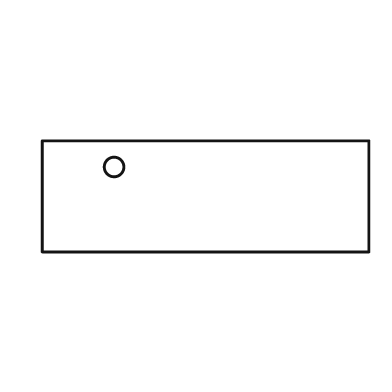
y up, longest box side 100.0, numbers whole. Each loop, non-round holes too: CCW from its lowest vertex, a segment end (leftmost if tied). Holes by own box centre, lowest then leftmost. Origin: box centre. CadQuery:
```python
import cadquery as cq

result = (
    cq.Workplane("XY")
    .moveTo(-50.0, -17.0)
    .lineTo(50.0, -17.0)
    .lineTo(50.0, 17.0)
    .lineTo(-50.0, 17.0)
    .close()
    .moveTo(-28.0, 9.0)
    .circle(3.0)
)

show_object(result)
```